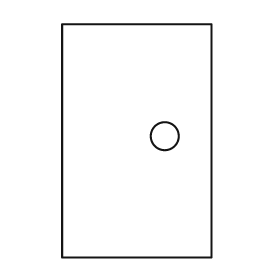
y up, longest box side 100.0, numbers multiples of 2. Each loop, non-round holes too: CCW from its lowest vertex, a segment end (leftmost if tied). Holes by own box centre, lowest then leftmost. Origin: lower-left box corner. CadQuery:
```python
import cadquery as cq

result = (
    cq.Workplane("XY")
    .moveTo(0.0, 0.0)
    .lineTo(64.0, 0.0)
    .lineTo(64.0, 100.0)
    .lineTo(0.0, 100.0)
    .close()
    .moveTo(44.0, 52.0)
    .circle(6.0)
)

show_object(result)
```